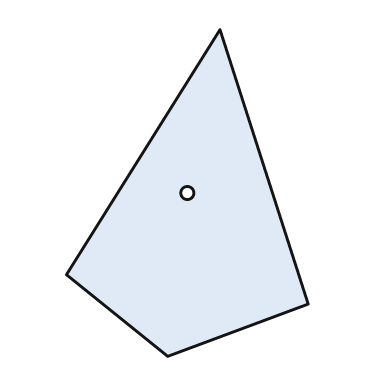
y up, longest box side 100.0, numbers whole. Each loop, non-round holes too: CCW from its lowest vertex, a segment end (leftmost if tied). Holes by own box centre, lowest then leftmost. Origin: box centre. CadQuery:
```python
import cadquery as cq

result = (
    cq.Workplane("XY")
    .moveTo(-6.0, -50.0)
    .lineTo(37.0, -34.0)
    .lineTo(10.0, 50.0)
    .lineTo(-37.0, -25.0)
    .close()
    .moveTo(0.0, 0.0)
    .circle(2.0)
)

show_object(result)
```